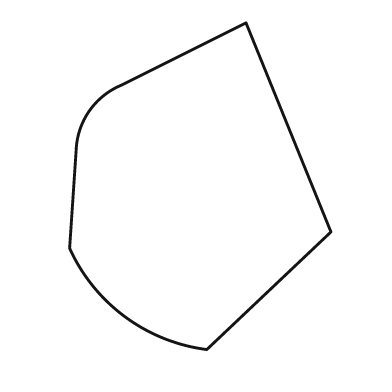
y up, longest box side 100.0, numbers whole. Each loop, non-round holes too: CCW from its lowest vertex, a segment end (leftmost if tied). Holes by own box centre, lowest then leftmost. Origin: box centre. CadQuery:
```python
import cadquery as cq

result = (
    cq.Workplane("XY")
    .moveTo(2.0, -50.0)
    .lineTo(40.0, -14.0)
    .lineTo(14.0, 50.0)
    .lineTo(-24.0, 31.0)
    .threePointArc((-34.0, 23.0), (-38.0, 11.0))
    .lineTo(-40.0, -19.0)
    .threePointArc((-23.0, -40.0), (2.0, -50.0))
    .close()
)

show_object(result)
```